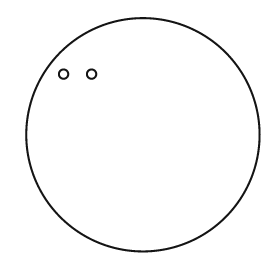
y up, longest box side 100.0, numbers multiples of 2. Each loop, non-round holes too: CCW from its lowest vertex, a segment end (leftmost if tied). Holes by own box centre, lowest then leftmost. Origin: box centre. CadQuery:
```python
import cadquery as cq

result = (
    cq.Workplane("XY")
    .moveTo(0.0, 0.0)
    .circle(50.0)
    .moveTo(-34.0, 26.0)
    .circle(2.0)
    .moveTo(-22.0, 26.0)
    .circle(2.0)
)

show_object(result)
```